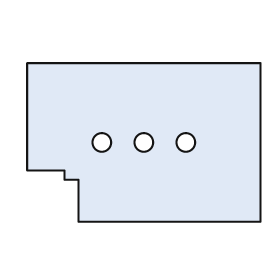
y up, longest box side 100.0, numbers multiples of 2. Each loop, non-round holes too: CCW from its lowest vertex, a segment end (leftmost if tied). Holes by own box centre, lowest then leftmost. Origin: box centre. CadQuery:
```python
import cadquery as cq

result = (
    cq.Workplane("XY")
    .moveTo(-28.0, -34.0)
    .lineTo(50.0, -34.0)
    .lineTo(50.0, 34.0)
    .lineTo(-50.0, 34.0)
    .lineTo(-50.0, -12.0)
    .lineTo(-34.0, -12.0)
    .lineTo(-34.0, -16.0)
    .lineTo(-28.0, -16.0)
    .close()
    .moveTo(-18.0, 0.0)
    .circle(4.0)
    .moveTo(0.0, 0.0)
    .circle(4.0)
    .moveTo(18.0, 0.0)
    .circle(4.0)
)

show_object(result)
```